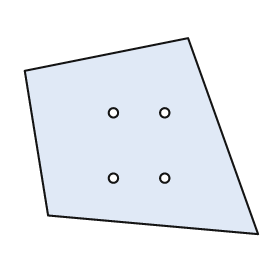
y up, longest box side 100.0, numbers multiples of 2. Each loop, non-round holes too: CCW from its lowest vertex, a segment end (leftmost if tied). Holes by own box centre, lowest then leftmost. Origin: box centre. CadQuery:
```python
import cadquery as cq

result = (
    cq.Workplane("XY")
    .moveTo(50.0, -42.0)
    .lineTo(20.0, 42.0)
    .lineTo(-50.0, 28.0)
    .lineTo(-40.0, -34.0)
    .close()
    .moveTo(-12.0, -18.0)
    .circle(2.0)
    .moveTo(10.0, -18.0)
    .circle(2.0)
    .moveTo(-12.0, 10.0)
    .circle(2.0)
    .moveTo(10.0, 10.0)
    .circle(2.0)
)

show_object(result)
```